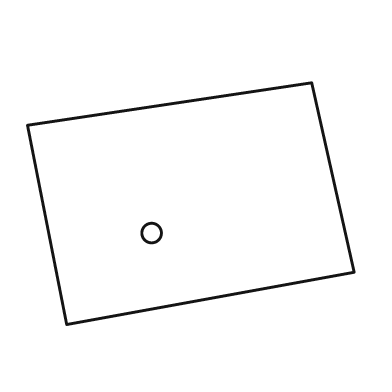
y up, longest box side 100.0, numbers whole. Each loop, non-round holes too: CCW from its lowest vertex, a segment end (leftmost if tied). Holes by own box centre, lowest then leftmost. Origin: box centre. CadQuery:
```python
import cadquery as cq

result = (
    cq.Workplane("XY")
    .moveTo(-38.0, -37.0)
    .lineTo(50.0, -21.0)
    .lineTo(37.0, 37.0)
    .lineTo(-50.0, 24.0)
    .close()
    .moveTo(-12.0, -9.0)
    .circle(3.0)
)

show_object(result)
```